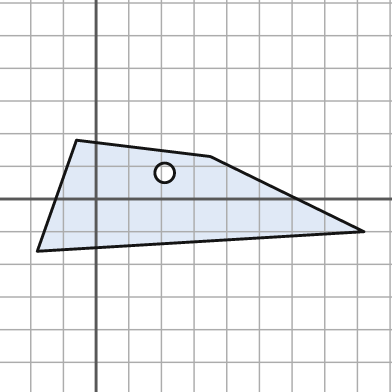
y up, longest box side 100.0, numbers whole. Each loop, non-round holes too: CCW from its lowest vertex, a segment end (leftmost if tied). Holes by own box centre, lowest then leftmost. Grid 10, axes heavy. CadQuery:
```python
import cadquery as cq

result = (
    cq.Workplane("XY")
    .moveTo(-18.0, -16.0)
    .lineTo(82.0, -10.0)
    .lineTo(35.0, 13.0)
    .lineTo(-6.0, 18.0)
    .close()
    .moveTo(21.0, 8.0)
    .circle(3.0)
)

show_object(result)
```